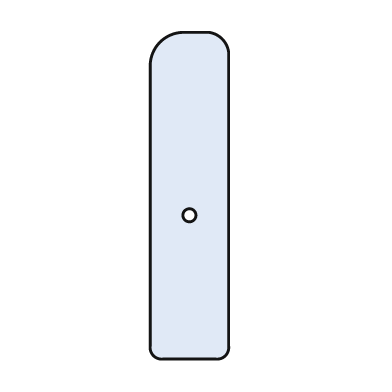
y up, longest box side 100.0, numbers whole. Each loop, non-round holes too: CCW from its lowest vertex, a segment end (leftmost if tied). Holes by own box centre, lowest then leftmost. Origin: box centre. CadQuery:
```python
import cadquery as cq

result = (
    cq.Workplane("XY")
    .moveTo(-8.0, -50.0)
    .lineTo(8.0, -50.0)
    .threePointArc((11.0, -49.0), (12.0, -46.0))
    .lineTo(12.0, 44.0)
    .threePointArc((10.0, 48.0), (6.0, 50.0))
    .lineTo(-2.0, 50.0)
    .threePointArc((-9.0, 47.0), (-12.0, 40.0))
    .lineTo(-12.0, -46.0)
    .threePointArc((-11.0, -49.0), (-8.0, -50.0))
    .close()
    .moveTo(0.0, -6.0)
    .circle(2.0)
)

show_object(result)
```